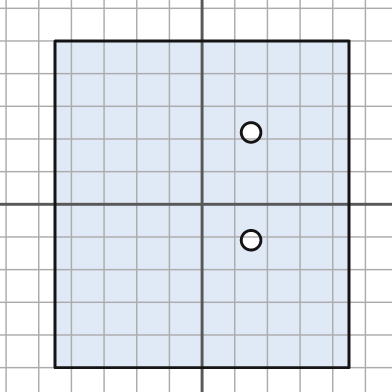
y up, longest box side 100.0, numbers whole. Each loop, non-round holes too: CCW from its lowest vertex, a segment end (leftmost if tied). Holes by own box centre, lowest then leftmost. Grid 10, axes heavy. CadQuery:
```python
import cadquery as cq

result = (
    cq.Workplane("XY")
    .moveTo(-45.0, -50.0)
    .lineTo(45.0, -50.0)
    .lineTo(45.0, 50.0)
    .lineTo(-45.0, 50.0)
    .close()
    .moveTo(15.0, -11.0)
    .circle(3.0)
    .moveTo(15.0, 22.0)
    .circle(3.0)
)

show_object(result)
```